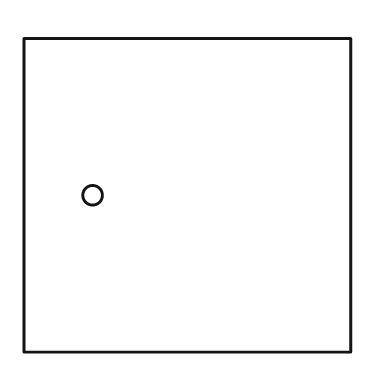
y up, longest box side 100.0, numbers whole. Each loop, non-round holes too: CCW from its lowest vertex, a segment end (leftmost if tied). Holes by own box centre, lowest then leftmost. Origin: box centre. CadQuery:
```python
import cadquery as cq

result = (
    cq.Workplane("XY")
    .moveTo(-50.0, -48.0)
    .lineTo(50.0, -48.0)
    .lineTo(50.0, 48.0)
    .lineTo(-50.0, 48.0)
    .close()
    .moveTo(-29.0, 0.0)
    .circle(3.0)
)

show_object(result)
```